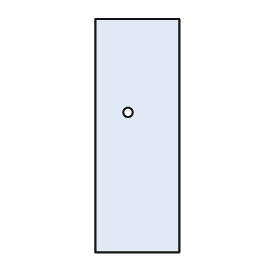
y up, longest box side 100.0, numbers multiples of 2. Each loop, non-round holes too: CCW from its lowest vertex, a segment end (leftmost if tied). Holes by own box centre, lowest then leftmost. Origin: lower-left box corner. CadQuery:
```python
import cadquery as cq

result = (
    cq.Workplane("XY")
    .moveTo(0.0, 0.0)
    .lineTo(36.0, 0.0)
    .lineTo(36.0, 100.0)
    .lineTo(0.0, 100.0)
    .close()
    .moveTo(14.0, 60.0)
    .circle(2.0)
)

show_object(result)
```